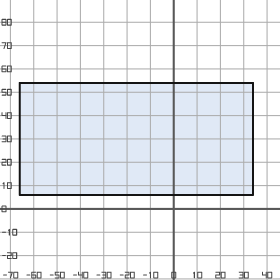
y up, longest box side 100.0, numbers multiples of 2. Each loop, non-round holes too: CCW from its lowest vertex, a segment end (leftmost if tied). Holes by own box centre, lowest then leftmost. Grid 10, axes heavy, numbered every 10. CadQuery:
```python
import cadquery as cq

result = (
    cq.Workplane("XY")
    .moveTo(-66.0, 6.0)
    .lineTo(34.0, 6.0)
    .lineTo(34.0, 54.0)
    .lineTo(-66.0, 54.0)
    .close()
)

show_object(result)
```